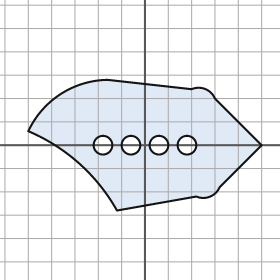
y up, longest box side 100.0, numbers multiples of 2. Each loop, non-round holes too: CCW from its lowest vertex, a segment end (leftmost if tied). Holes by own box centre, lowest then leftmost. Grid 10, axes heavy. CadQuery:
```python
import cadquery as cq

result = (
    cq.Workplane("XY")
    .moveTo(-12.0, -28.0)
    .lineTo(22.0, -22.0)
    .threePointArc((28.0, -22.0), (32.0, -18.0))
    .lineTo(50.0, 0.0)
    .lineTo(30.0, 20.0)
    .threePointArc((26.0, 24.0), (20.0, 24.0))
    .lineTo(-16.0, 28.0)
    .threePointArc((-36.0, 22.0), (-50.0, 6.0))
    .threePointArc((-28.0, -8.0), (-12.0, -28.0))
    .close()
    .moveTo(-18.0, 0.0)
    .circle(4.0)
    .moveTo(-6.0, 0.0)
    .circle(4.0)
    .moveTo(6.0, 0.0)
    .circle(4.0)
    .moveTo(18.0, 0.0)
    .circle(4.0)
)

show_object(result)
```